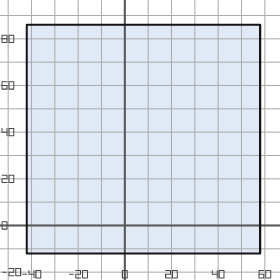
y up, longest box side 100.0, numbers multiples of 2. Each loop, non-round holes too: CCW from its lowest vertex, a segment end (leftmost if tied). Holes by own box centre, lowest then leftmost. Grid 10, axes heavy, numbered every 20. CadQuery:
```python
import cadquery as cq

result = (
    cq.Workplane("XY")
    .moveTo(-42.0, -12.0)
    .lineTo(58.0, -12.0)
    .lineTo(58.0, 86.0)
    .lineTo(-42.0, 86.0)
    .close()
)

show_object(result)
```